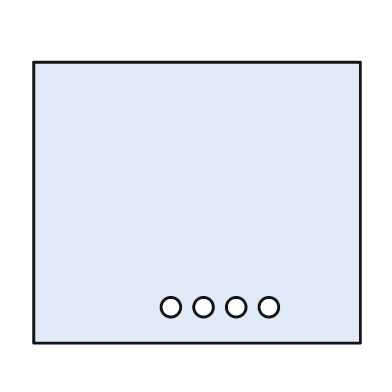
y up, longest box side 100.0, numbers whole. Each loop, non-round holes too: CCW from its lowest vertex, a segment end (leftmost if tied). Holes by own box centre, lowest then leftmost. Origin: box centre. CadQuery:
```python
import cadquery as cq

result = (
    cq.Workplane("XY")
    .moveTo(-50.0, -43.0)
    .lineTo(50.0, -43.0)
    .lineTo(50.0, 43.0)
    .lineTo(-50.0, 43.0)
    .close()
    .moveTo(-8.0, -32.0)
    .circle(3.0)
    .moveTo(2.0, -32.0)
    .circle(3.0)
    .moveTo(12.0, -32.0)
    .circle(3.0)
    .moveTo(22.0, -32.0)
    .circle(3.0)
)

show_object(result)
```